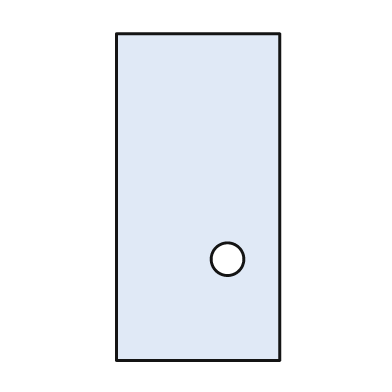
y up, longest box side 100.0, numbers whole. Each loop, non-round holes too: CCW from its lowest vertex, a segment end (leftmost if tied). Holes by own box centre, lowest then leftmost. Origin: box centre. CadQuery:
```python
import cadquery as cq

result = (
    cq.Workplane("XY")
    .moveTo(-25.0, -50.0)
    .lineTo(25.0, -50.0)
    .lineTo(25.0, 50.0)
    .lineTo(-25.0, 50.0)
    .close()
    .moveTo(9.0, -19.0)
    .circle(5.0)
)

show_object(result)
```